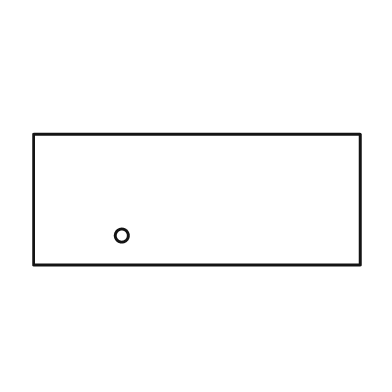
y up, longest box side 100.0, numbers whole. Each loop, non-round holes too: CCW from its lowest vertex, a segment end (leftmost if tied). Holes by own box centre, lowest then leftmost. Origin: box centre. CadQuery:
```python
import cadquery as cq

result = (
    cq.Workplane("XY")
    .moveTo(-50.0, -20.0)
    .lineTo(50.0, -20.0)
    .lineTo(50.0, 20.0)
    .lineTo(-50.0, 20.0)
    .close()
    .moveTo(-23.0, -11.0)
    .circle(2.0)
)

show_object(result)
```